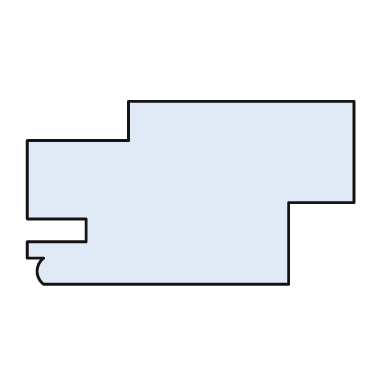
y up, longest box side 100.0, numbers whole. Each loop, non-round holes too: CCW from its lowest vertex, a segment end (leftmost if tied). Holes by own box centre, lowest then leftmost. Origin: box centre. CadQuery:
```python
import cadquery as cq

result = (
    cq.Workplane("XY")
    .moveTo(-45.0, -28.0)
    .lineTo(30.0, -28.0)
    .lineTo(30.0, -3.0)
    .lineTo(50.0, -3.0)
    .lineTo(50.0, 28.0)
    .lineTo(-19.0, 28.0)
    .lineTo(-19.0, 16.0)
    .lineTo(-50.0, 16.0)
    .lineTo(-50.0, -8.0)
    .lineTo(-32.0, -8.0)
    .lineTo(-32.0, -15.0)
    .lineTo(-50.0, -15.0)
    .lineTo(-50.0, -20.0)
    .lineTo(-45.0, -20.0)
    .threePointArc((-47.0, -24.0), (-45.0, -28.0))
    .close()
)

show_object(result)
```